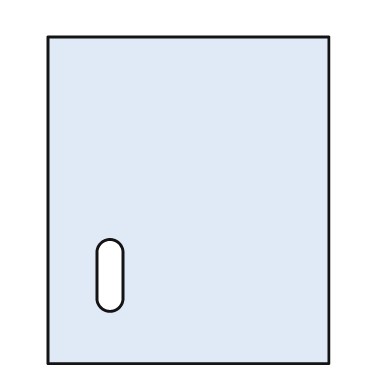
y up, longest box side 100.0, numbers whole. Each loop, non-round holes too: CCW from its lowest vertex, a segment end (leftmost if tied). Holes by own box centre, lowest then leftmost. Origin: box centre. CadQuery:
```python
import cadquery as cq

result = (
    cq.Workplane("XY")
    .moveTo(-43.0, -50.0)
    .lineTo(43.0, -50.0)
    .lineTo(43.0, 50.0)
    .lineTo(-43.0, 50.0)
    .close()
    .moveTo(-28.0, -30.0)
    .threePointArc((-24.0, -34.0), (-20.0, -30.0))
    .lineTo(-20.0, -16.0)
    .threePointArc((-24.0, -12.0), (-28.0, -16.0))
    .close()
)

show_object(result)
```